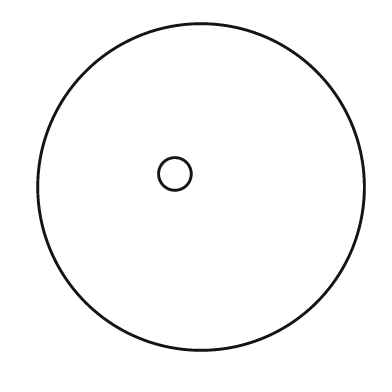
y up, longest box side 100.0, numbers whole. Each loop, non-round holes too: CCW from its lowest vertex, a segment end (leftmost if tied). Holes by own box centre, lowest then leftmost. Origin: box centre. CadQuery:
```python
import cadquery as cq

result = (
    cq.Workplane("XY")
    .moveTo(0.0, 0.0)
    .circle(50.0)
    .moveTo(-8.0, 4.0)
    .circle(5.0)
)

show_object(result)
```